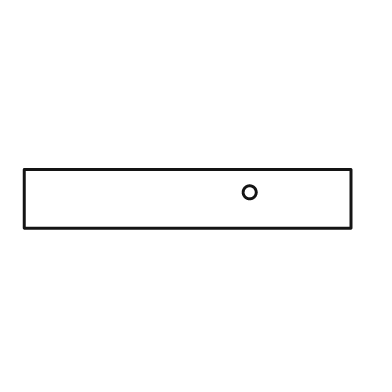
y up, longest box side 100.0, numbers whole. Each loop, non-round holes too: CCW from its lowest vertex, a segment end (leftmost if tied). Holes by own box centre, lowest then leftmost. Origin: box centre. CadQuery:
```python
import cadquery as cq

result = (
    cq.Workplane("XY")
    .moveTo(-50.0, -9.0)
    .lineTo(50.0, -9.0)
    .lineTo(50.0, 9.0)
    .lineTo(-50.0, 9.0)
    .close()
    .moveTo(19.0, 2.0)
    .circle(2.0)
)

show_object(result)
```